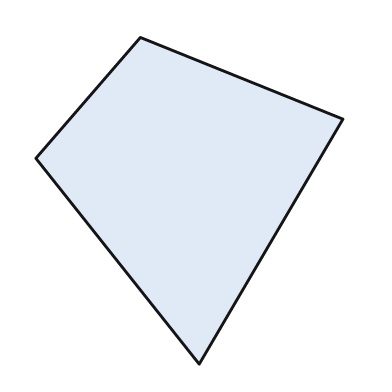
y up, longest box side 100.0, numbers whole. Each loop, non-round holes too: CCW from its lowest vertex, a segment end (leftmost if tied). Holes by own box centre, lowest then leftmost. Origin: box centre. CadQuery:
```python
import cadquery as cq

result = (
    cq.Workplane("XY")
    .moveTo(3.0, -50.0)
    .lineTo(47.0, 25.0)
    .lineTo(-15.0, 50.0)
    .lineTo(-47.0, 13.0)
    .close()
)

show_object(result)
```